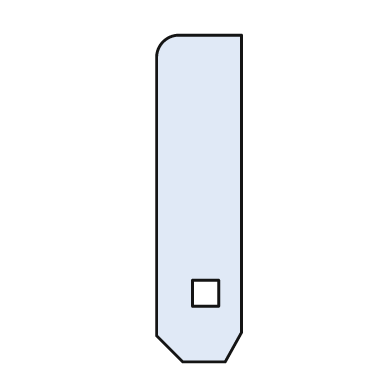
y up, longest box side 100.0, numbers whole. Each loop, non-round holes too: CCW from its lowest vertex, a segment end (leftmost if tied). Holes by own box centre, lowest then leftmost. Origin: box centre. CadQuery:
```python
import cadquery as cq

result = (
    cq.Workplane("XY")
    .moveTo(-5.0, -50.0)
    .lineTo(8.0, -50.0)
    .lineTo(13.0, -41.0)
    .lineTo(13.0, 50.0)
    .lineTo(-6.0, 50.0)
    .threePointArc((-11.0, 48.0), (-13.0, 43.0))
    .lineTo(-13.0, -42.0)
    .close()
    .moveTo(-2.0, -33.0)
    .lineTo(6.0, -33.0)
    .lineTo(6.0, -25.0)
    .lineTo(-2.0, -25.0)
    .close()
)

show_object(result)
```